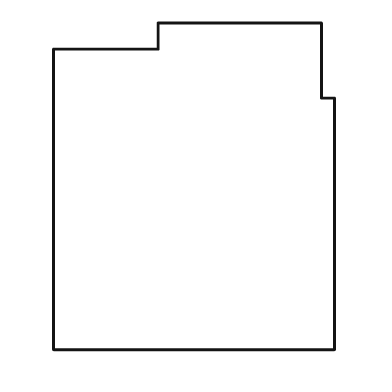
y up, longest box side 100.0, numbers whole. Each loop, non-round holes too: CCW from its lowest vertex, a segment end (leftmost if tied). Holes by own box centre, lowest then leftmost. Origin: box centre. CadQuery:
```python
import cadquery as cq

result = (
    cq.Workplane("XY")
    .moveTo(-43.0, -50.0)
    .lineTo(43.0, -50.0)
    .lineTo(43.0, 27.0)
    .lineTo(39.0, 27.0)
    .lineTo(39.0, 50.0)
    .lineTo(-11.0, 50.0)
    .lineTo(-11.0, 42.0)
    .lineTo(-43.0, 42.0)
    .close()
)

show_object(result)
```